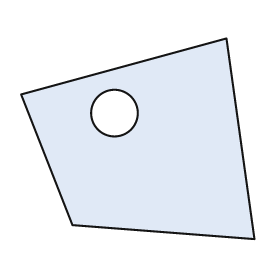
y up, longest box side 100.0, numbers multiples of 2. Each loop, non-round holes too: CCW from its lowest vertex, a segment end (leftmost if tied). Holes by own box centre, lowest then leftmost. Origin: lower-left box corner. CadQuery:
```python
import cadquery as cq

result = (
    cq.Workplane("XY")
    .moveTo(100.0, 0.0)
    .lineTo(88.0, 86.0)
    .lineTo(0.0, 62.0)
    .lineTo(22.0, 6.0)
    .close()
    .moveTo(40.0, 54.0)
    .circle(10.0)
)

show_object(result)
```